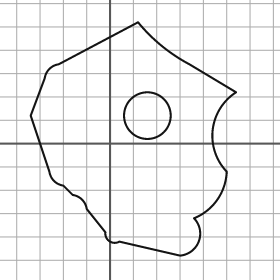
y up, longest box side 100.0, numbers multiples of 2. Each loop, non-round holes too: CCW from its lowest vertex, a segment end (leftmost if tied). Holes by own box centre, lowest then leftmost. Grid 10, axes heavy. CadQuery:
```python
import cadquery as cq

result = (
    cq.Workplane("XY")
    .moveTo(30.0, -48.0)
    .threePointArc((38.0, -42.0), (36.0, -32.0))
    .threePointArc((46.0, -24.0), (50.0, -12.0))
    .threePointArc((44.0, 6.0), (54.0, 22.0))
    .lineTo(34.0, 34.0)
    .threePointArc((22.0, 42.0), (12.0, 52.0))
    .lineTo(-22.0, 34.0)
    .threePointArc((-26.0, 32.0), (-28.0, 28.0))
    .lineTo(-34.0, 12.0)
    .lineTo(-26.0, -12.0)
    .threePointArc((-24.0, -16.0), (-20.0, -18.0))
    .lineTo(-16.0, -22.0)
    .threePointArc((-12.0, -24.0), (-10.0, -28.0))
    .lineTo(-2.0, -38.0)
    .threePointArc((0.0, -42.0), (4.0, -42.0))
    .close()
    .moveTo(16.0, 12.0)
    .circle(10.0)
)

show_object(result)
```